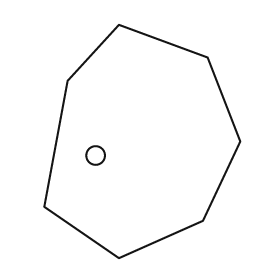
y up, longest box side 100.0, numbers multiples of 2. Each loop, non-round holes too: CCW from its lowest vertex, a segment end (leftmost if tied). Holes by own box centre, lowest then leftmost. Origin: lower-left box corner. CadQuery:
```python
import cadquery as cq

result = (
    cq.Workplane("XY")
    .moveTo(32.0, 0.0)
    .lineTo(68.0, 16.0)
    .lineTo(84.0, 50.0)
    .lineTo(70.0, 86.0)
    .lineTo(32.0, 100.0)
    .lineTo(10.0, 76.0)
    .lineTo(0.0, 22.0)
    .close()
    .moveTo(22.0, 44.0)
    .circle(4.0)
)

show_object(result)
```